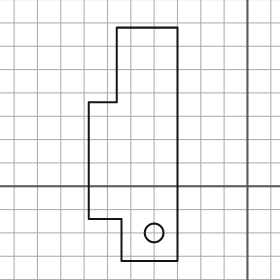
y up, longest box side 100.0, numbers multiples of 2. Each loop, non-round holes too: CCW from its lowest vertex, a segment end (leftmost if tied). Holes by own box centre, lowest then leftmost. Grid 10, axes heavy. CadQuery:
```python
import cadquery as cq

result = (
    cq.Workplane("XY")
    .moveTo(-54.0, -32.0)
    .lineTo(-30.0, -32.0)
    .lineTo(-30.0, 68.0)
    .lineTo(-56.0, 68.0)
    .lineTo(-56.0, 36.0)
    .lineTo(-68.0, 36.0)
    .lineTo(-68.0, -14.0)
    .lineTo(-54.0, -14.0)
    .close()
    .moveTo(-40.0, -20.0)
    .circle(4.0)
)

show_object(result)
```